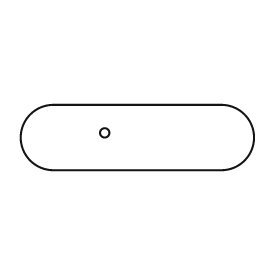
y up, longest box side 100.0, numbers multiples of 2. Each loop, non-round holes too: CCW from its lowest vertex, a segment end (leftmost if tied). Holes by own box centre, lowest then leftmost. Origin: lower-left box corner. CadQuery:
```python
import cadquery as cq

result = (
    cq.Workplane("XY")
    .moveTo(14.0, 0.0)
    .lineTo(86.0, 0.0)
    .threePointArc((100.0, 14.0), (86.0, 28.0))
    .lineTo(14.0, 28.0)
    .threePointArc((0.0, 14.0), (14.0, 0.0))
    .close()
    .moveTo(36.0, 16.0)
    .circle(2.0)
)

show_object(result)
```